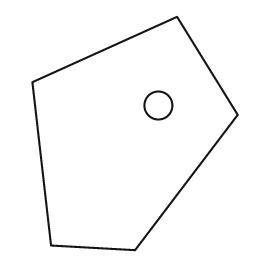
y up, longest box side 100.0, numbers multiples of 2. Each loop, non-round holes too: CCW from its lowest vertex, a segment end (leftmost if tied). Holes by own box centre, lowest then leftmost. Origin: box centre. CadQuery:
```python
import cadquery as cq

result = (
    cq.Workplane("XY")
    .moveTo(0.0, -50.0)
    .lineTo(44.0, 8.0)
    .lineTo(18.0, 50.0)
    .lineTo(-44.0, 22.0)
    .lineTo(-36.0, -48.0)
    .close()
    .moveTo(10.0, 12.0)
    .circle(6.0)
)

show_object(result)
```